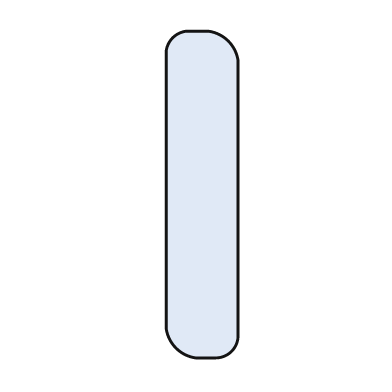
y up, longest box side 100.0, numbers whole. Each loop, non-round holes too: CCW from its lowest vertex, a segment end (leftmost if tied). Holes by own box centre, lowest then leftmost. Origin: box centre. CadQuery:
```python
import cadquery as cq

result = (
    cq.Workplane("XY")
    .moveTo(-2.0, -50.0)
    .lineTo(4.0, -50.0)
    .threePointArc((9.0, -48.0), (11.0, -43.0))
    .lineTo(11.0, 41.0)
    .threePointArc((8.0, 47.0), (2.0, 50.0))
    .lineTo(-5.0, 50.0)
    .threePointArc((-9.0, 48.0), (-11.0, 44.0))
    .lineTo(-11.0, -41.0)
    .threePointArc((-8.0, -47.0), (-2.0, -50.0))
    .close()
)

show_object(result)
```